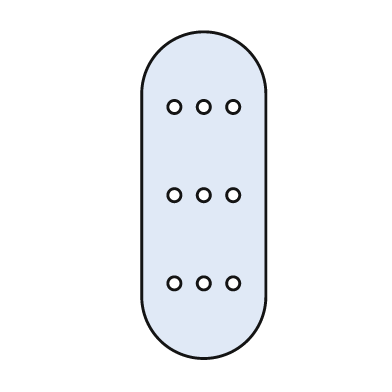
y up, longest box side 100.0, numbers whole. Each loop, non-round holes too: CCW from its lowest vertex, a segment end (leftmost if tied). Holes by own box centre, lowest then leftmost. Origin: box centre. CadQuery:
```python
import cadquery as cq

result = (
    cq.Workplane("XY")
    .moveTo(-19.0, -31.0)
    .threePointArc((0.0, -50.0), (19.0, -31.0))
    .lineTo(19.0, 31.0)
    .threePointArc((0.0, 50.0), (-19.0, 31.0))
    .close()
    .moveTo(-9.0, -27.0)
    .circle(2.0)
    .moveTo(0.0, -27.0)
    .circle(2.0)
    .moveTo(9.0, -27.0)
    .circle(2.0)
    .moveTo(-9.0, 0.0)
    .circle(2.0)
    .moveTo(0.0, 0.0)
    .circle(2.0)
    .moveTo(9.0, 0.0)
    .circle(2.0)
    .moveTo(-9.0, 27.0)
    .circle(2.0)
    .moveTo(0.0, 27.0)
    .circle(2.0)
    .moveTo(9.0, 27.0)
    .circle(2.0)
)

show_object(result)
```